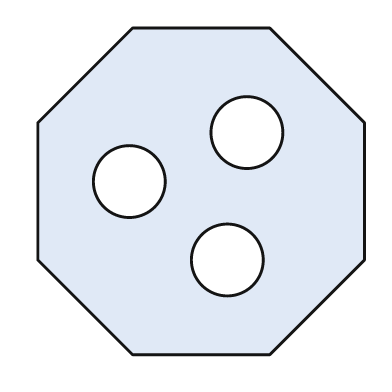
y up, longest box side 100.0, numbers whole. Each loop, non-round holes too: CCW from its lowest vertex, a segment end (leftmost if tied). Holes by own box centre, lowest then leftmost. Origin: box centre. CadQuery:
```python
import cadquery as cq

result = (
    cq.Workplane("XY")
    .moveTo(-21.0, -50.0)
    .lineTo(21.0, -50.0)
    .lineTo(50.0, -21.0)
    .lineTo(50.0, 21.0)
    .lineTo(21.0, 50.0)
    .lineTo(-21.0, 50.0)
    .lineTo(-50.0, 21.0)
    .lineTo(-50.0, -21.0)
    .close()
    .moveTo(8.0, -21.0)
    .circle(11.0)
    .moveTo(-22.0, 3.0)
    .circle(11.0)
    .moveTo(14.0, 18.0)
    .circle(11.0)
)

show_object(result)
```